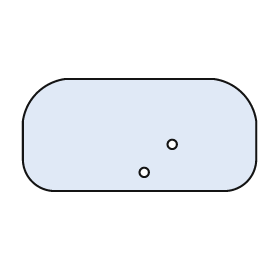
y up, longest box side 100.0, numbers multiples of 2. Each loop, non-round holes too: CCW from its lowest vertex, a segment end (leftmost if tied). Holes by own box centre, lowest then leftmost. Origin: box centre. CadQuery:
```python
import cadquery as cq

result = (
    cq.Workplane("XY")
    .moveTo(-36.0, -24.0)
    .lineTo(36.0, -24.0)
    .threePointArc((46.0, -20.0), (50.0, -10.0))
    .lineTo(50.0, 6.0)
    .threePointArc((44.0, 18.0), (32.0, 24.0))
    .lineTo(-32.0, 24.0)
    .threePointArc((-44.0, 18.0), (-50.0, 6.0))
    .lineTo(-50.0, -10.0)
    .threePointArc((-46.0, -20.0), (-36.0, -24.0))
    .close()
    .moveTo(2.0, -16.0)
    .circle(2.0)
    .moveTo(14.0, -4.0)
    .circle(2.0)
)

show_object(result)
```